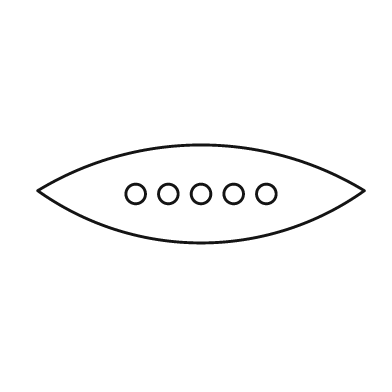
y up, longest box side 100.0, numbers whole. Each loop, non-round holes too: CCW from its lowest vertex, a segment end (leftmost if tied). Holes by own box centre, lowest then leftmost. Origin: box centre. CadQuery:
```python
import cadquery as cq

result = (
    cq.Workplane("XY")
    .moveTo(-50.0, 1.0)
    .threePointArc((0.0, -15.0), (50.0, 1.0))
    .threePointArc((0.0, 15.0), (-50.0, 1.0))
    .close()
    .moveTo(-20.0, 0.0)
    .circle(3.0)
    .moveTo(-10.0, 0.0)
    .circle(3.0)
    .moveTo(0.0, 0.0)
    .circle(3.0)
    .moveTo(10.0, 0.0)
    .circle(3.0)
    .moveTo(20.0, 0.0)
    .circle(3.0)
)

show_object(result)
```